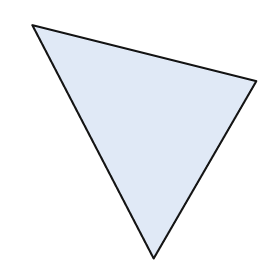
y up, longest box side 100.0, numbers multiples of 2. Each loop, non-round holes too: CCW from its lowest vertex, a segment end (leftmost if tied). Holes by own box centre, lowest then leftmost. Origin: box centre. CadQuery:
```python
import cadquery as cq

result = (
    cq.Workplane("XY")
    .moveTo(4.0, -50.0)
    .lineTo(48.0, 26.0)
    .lineTo(-48.0, 50.0)
    .close()
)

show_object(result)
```